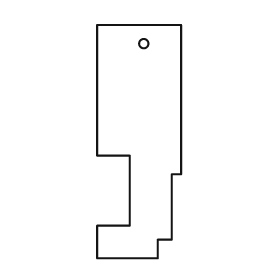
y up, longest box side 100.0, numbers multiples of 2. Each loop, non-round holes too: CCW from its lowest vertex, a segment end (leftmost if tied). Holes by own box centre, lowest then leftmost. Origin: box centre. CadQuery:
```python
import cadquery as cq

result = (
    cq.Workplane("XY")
    .moveTo(-18.0, -50.0)
    .lineTo(8.0, -50.0)
    .lineTo(8.0, -42.0)
    .lineTo(14.0, -42.0)
    .lineTo(14.0, -14.0)
    .lineTo(18.0, -14.0)
    .lineTo(18.0, 50.0)
    .lineTo(-18.0, 50.0)
    .lineTo(-18.0, -6.0)
    .lineTo(-4.0, -6.0)
    .lineTo(-4.0, -36.0)
    .lineTo(-18.0, -36.0)
    .close()
    .moveTo(2.0, 42.0)
    .circle(2.0)
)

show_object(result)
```